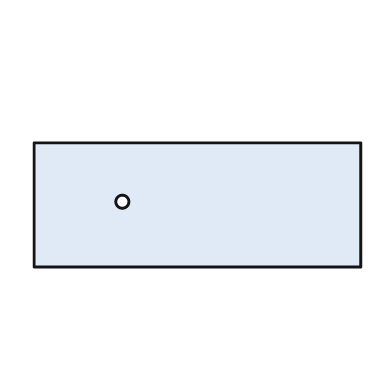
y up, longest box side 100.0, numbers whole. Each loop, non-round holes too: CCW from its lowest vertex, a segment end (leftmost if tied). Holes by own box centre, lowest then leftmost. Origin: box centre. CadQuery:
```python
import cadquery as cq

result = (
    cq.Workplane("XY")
    .moveTo(-50.0, -19.0)
    .lineTo(50.0, -19.0)
    .lineTo(50.0, 19.0)
    .lineTo(-50.0, 19.0)
    .close()
    .moveTo(-23.0, 1.0)
    .circle(2.0)
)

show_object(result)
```